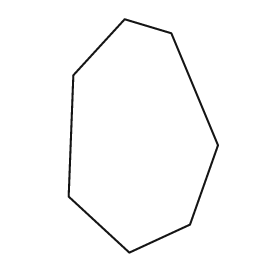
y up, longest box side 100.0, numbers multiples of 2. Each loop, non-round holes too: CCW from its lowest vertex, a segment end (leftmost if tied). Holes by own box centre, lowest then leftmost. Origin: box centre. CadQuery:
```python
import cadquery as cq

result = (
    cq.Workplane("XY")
    .moveTo(-6.0, -50.0)
    .lineTo(20.0, -38.0)
    .lineTo(32.0, -4.0)
    .lineTo(12.0, 44.0)
    .lineTo(-8.0, 50.0)
    .lineTo(-30.0, 26.0)
    .lineTo(-32.0, -26.0)
    .close()
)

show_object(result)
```